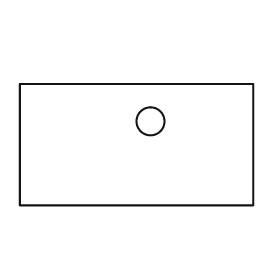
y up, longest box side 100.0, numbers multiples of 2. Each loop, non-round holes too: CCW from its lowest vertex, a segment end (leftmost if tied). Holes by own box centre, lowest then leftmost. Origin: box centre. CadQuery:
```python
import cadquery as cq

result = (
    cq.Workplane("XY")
    .moveTo(-50.0, -26.0)
    .lineTo(50.0, -26.0)
    .lineTo(50.0, 26.0)
    .lineTo(-50.0, 26.0)
    .close()
    .moveTo(6.0, 10.0)
    .circle(6.0)
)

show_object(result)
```